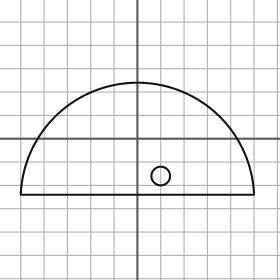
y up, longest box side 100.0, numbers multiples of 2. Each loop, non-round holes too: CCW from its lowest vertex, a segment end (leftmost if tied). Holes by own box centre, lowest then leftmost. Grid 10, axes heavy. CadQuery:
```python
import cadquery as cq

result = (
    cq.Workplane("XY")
    .moveTo(-50.0, -24.0)
    .lineTo(50.0, -24.0)
    .threePointArc((0.0, 24.0), (-50.0, -24.0))
    .close()
    .moveTo(10.0, -16.0)
    .circle(4.0)
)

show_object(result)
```